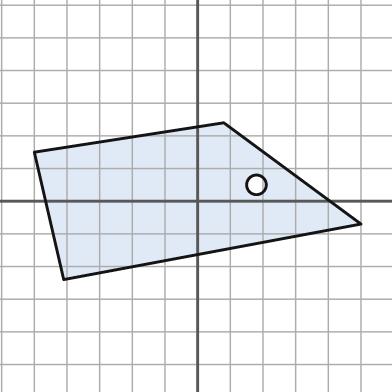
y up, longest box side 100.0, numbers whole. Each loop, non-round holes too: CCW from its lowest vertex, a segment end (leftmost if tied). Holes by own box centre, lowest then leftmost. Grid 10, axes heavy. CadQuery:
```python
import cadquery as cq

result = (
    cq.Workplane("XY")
    .moveTo(-41.0, -24.0)
    .lineTo(50.0, -7.0)
    .lineTo(8.0, 24.0)
    .lineTo(-50.0, 15.0)
    .close()
    .moveTo(18.0, 5.0)
    .circle(3.0)
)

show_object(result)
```